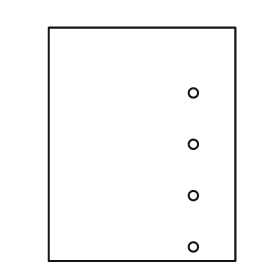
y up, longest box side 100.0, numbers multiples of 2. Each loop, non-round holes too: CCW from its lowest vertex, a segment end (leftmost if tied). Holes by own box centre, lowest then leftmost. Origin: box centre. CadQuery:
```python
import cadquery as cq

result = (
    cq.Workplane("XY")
    .moveTo(-40.0, -50.0)
    .lineTo(40.0, -50.0)
    .lineTo(40.0, 50.0)
    .lineTo(-40.0, 50.0)
    .close()
    .moveTo(22.0, -44.0)
    .circle(2.0)
    .moveTo(22.0, -22.0)
    .circle(2.0)
    .moveTo(22.0, 0.0)
    .circle(2.0)
    .moveTo(22.0, 22.0)
    .circle(2.0)
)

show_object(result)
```